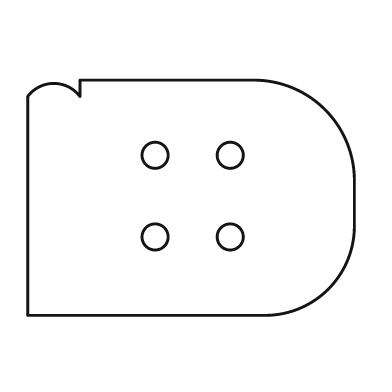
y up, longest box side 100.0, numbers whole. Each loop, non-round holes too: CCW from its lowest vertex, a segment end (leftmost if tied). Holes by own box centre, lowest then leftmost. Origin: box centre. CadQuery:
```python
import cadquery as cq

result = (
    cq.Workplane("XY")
    .moveTo(-50.0, -36.0)
    .lineTo(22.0, -36.0)
    .threePointArc((42.0, -28.0), (50.0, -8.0))
    .lineTo(50.0, 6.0)
    .threePointArc((41.0, 27.0), (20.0, 36.0))
    .lineTo(-34.0, 36.0)
    .lineTo(-34.0, 31.0)
    .threePointArc((-42.0, 35.0), (-50.0, 31.0))
    .close()
    .moveTo(-11.0, -12.0)
    .circle(4.0)
    .moveTo(12.0, -12.0)
    .circle(4.0)
    .moveTo(-11.0, 13.0)
    .circle(4.0)
    .moveTo(12.0, 13.0)
    .circle(4.0)
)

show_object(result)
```